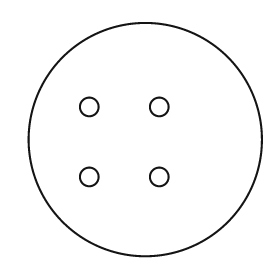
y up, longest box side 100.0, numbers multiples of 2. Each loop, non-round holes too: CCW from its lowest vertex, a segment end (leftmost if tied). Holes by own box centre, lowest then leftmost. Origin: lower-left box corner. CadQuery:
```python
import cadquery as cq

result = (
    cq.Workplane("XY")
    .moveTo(50.0, 50.0)
    .circle(50.0)
    .moveTo(26.0, 34.0)
    .circle(4.0)
    .moveTo(56.0, 34.0)
    .circle(4.0)
    .moveTo(26.0, 64.0)
    .circle(4.0)
    .moveTo(56.0, 64.0)
    .circle(4.0)
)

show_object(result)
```